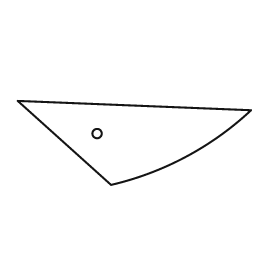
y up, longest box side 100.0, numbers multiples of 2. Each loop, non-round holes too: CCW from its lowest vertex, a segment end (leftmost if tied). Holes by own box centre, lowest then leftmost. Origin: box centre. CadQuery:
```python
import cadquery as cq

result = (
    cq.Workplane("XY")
    .moveTo(-10.0, -18.0)
    .threePointArc((22.0, -6.0), (50.0, 14.0))
    .lineTo(-50.0, 18.0)
    .close()
    .moveTo(-16.0, 4.0)
    .circle(2.0)
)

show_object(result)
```